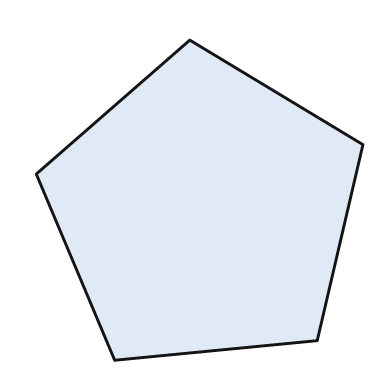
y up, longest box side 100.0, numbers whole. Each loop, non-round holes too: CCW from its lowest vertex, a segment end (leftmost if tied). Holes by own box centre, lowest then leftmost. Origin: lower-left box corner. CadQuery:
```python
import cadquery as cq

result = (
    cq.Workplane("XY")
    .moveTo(24.0, 0.0)
    .lineTo(86.0, 6.0)
    .lineTo(100.0, 66.0)
    .lineTo(47.0, 98.0)
    .lineTo(0.0, 57.0)
    .close()
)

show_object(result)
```